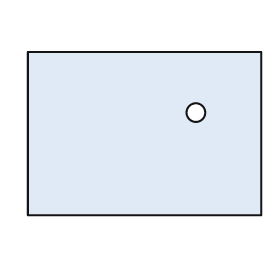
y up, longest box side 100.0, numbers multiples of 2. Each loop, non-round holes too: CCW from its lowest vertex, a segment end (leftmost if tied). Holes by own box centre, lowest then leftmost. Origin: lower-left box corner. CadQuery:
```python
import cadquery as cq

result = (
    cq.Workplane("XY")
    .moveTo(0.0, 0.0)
    .lineTo(100.0, 0.0)
    .lineTo(100.0, 70.0)
    .lineTo(0.0, 70.0)
    .close()
    .moveTo(72.0, 44.0)
    .circle(4.0)
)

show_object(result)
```